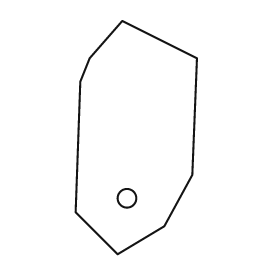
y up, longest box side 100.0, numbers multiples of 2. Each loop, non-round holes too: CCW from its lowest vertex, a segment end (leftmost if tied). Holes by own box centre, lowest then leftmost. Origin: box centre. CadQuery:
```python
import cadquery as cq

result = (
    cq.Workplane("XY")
    .moveTo(-8.0, -50.0)
    .lineTo(12.0, -38.0)
    .lineTo(24.0, -16.0)
    .lineTo(26.0, 34.0)
    .lineTo(-6.0, 50.0)
    .lineTo(-20.0, 34.0)
    .lineTo(-24.0, 24.0)
    .lineTo(-26.0, -32.0)
    .close()
    .moveTo(-4.0, -26.0)
    .circle(4.0)
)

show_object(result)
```